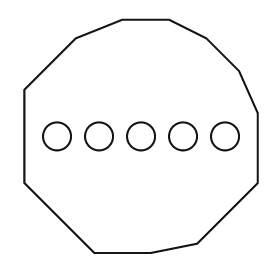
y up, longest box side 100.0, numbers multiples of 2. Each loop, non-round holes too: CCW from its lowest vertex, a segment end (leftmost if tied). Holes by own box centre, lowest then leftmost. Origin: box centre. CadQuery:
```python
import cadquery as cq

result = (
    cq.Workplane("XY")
    .moveTo(-20.0, -50.0)
    .lineTo(4.0, -50.0)
    .lineTo(24.0, -46.0)
    .lineTo(50.0, -20.0)
    .lineTo(50.0, 10.0)
    .lineTo(42.0, 28.0)
    .lineTo(28.0, 42.0)
    .lineTo(12.0, 50.0)
    .lineTo(-8.0, 50.0)
    .lineTo(-28.0, 42.0)
    .lineTo(-50.0, 20.0)
    .lineTo(-50.0, -20.0)
    .close()
    .moveTo(-36.0, 0.0)
    .circle(6.0)
    .moveTo(-18.0, 0.0)
    .circle(6.0)
    .moveTo(0.0, 0.0)
    .circle(6.0)
    .moveTo(18.0, 0.0)
    .circle(6.0)
    .moveTo(36.0, 0.0)
    .circle(6.0)
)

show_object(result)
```